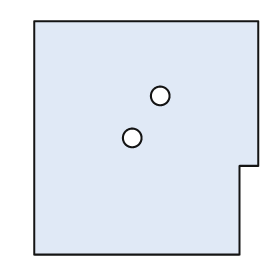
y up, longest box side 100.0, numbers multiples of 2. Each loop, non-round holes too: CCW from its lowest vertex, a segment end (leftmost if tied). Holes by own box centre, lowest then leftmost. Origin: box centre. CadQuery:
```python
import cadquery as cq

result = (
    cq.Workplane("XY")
    .moveTo(-48.0, -50.0)
    .lineTo(40.0, -50.0)
    .lineTo(40.0, -12.0)
    .lineTo(48.0, -12.0)
    .lineTo(48.0, 50.0)
    .lineTo(-48.0, 50.0)
    .close()
    .moveTo(-6.0, 0.0)
    .circle(4.0)
    .moveTo(6.0, 18.0)
    .circle(4.0)
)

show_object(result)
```